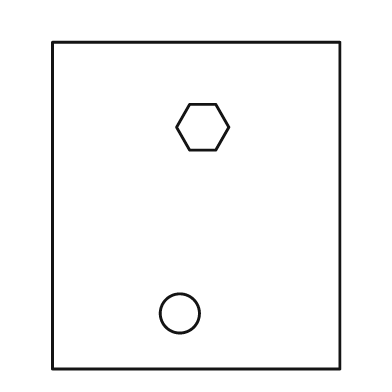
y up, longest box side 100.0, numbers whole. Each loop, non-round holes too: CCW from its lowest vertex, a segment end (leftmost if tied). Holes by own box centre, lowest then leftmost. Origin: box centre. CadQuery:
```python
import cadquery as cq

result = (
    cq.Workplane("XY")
    .moveTo(-44.0, -50.0)
    .lineTo(44.0, -50.0)
    .lineTo(44.0, 50.0)
    .lineTo(-44.0, 50.0)
    .close()
    .moveTo(-5.0, -33.0)
    .circle(6.0)
    .moveTo(-2.0, 17.0)
    .lineTo(6.0, 17.0)
    .lineTo(10.0, 24.0)
    .lineTo(6.0, 31.0)
    .lineTo(-2.0, 31.0)
    .lineTo(-6.0, 24.0)
    .close()
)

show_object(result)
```